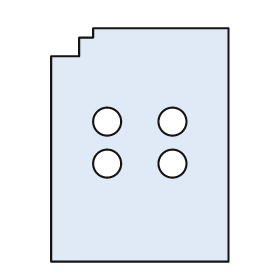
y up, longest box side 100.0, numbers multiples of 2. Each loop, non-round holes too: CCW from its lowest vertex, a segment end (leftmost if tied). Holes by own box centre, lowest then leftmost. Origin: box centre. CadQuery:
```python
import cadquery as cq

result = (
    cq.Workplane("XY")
    .moveTo(-38.0, -50.0)
    .lineTo(38.0, -50.0)
    .lineTo(38.0, 50.0)
    .lineTo(-20.0, 50.0)
    .lineTo(-20.0, 46.0)
    .lineTo(-26.0, 46.0)
    .lineTo(-26.0, 38.0)
    .lineTo(-38.0, 38.0)
    .close()
    .moveTo(-14.0, -8.0)
    .circle(6.0)
    .moveTo(14.0, -8.0)
    .circle(6.0)
    .moveTo(-14.0, 10.0)
    .circle(6.0)
    .moveTo(14.0, 10.0)
    .circle(6.0)
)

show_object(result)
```